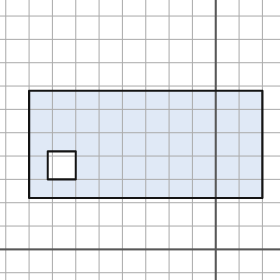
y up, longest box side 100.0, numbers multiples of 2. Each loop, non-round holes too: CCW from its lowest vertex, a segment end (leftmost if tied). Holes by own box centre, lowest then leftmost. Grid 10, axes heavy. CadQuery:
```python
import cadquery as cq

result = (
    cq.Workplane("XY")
    .moveTo(-80.0, 22.0)
    .lineTo(20.0, 22.0)
    .lineTo(20.0, 68.0)
    .lineTo(-80.0, 68.0)
    .close()
    .moveTo(-72.0, 30.0)
    .lineTo(-60.0, 30.0)
    .lineTo(-60.0, 42.0)
    .lineTo(-72.0, 42.0)
    .close()
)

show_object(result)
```